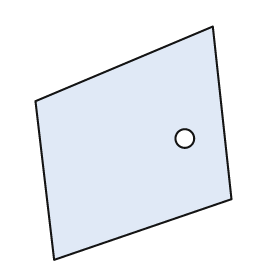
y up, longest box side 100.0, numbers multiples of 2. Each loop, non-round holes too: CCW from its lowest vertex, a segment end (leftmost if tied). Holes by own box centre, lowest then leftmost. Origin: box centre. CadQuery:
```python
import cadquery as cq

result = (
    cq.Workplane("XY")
    .moveTo(-34.0, -50.0)
    .lineTo(42.0, -24.0)
    .lineTo(34.0, 50.0)
    .lineTo(-42.0, 18.0)
    .close()
    .moveTo(22.0, 2.0)
    .circle(4.0)
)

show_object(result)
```